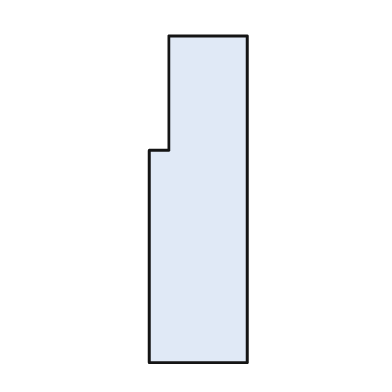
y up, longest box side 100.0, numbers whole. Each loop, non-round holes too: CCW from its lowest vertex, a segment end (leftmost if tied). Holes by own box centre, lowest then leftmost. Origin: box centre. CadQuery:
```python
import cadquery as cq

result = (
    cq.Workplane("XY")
    .moveTo(-15.0, -50.0)
    .lineTo(15.0, -50.0)
    .lineTo(15.0, 50.0)
    .lineTo(-9.0, 50.0)
    .lineTo(-9.0, 15.0)
    .lineTo(-15.0, 15.0)
    .close()
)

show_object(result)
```